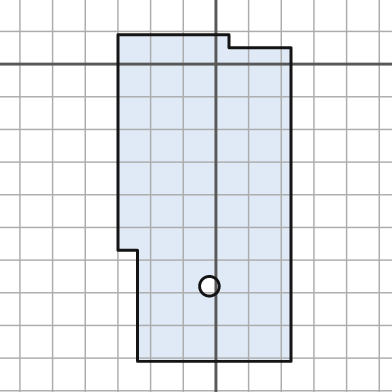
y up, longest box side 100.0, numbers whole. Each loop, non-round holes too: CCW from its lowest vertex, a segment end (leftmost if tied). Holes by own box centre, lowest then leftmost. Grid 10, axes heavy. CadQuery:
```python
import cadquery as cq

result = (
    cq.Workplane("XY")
    .moveTo(-24.0, -91.0)
    .lineTo(23.0, -91.0)
    .lineTo(23.0, 5.0)
    .lineTo(4.0, 5.0)
    .lineTo(4.0, 9.0)
    .lineTo(-30.0, 9.0)
    .lineTo(-30.0, -57.0)
    .lineTo(-24.0, -57.0)
    .close()
    .moveTo(-2.0, -68.0)
    .circle(3.0)
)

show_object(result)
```